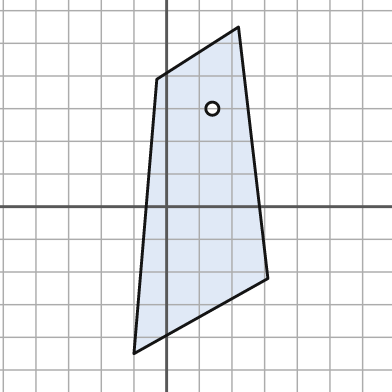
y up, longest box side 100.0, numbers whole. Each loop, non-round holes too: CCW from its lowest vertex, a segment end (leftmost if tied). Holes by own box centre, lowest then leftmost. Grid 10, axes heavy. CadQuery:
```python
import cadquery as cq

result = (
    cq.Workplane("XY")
    .moveTo(-10.0, -45.0)
    .lineTo(31.0, -22.0)
    .lineTo(22.0, 55.0)
    .lineTo(-3.0, 39.0)
    .close()
    .moveTo(14.0, 30.0)
    .circle(2.0)
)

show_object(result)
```